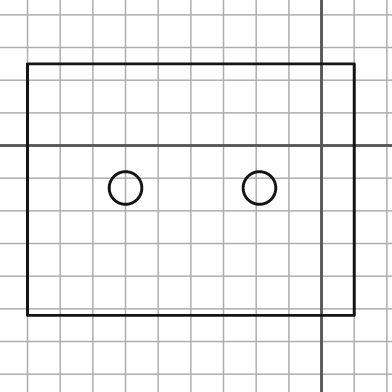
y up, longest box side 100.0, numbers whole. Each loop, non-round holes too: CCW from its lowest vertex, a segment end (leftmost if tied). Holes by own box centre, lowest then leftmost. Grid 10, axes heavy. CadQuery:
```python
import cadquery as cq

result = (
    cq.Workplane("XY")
    .moveTo(-90.0, -52.0)
    .lineTo(10.0, -52.0)
    .lineTo(10.0, 25.0)
    .lineTo(-90.0, 25.0)
    .close()
    .moveTo(-60.0, -13.0)
    .circle(5.0)
    .moveTo(-19.0, -13.0)
    .circle(5.0)
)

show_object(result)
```